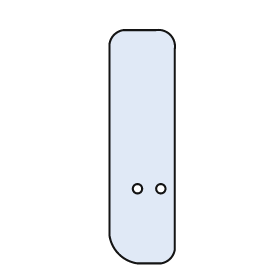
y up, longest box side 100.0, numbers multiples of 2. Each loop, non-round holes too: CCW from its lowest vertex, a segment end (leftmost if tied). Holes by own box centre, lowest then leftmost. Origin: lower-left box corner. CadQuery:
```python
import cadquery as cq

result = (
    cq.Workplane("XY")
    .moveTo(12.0, 0.0)
    .lineTo(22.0, 0.0)
    .threePointArc((26.0, 2.0), (28.0, 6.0))
    .lineTo(28.0, 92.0)
    .threePointArc((26.0, 98.0), (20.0, 100.0))
    .lineTo(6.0, 100.0)
    .threePointArc((2.0, 98.0), (0.0, 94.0))
    .lineTo(0.0, 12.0)
    .threePointArc((4.0, 4.0), (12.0, 0.0))
    .close()
    .moveTo(12.0, 32.0)
    .circle(2.0)
    .moveTo(22.0, 32.0)
    .circle(2.0)
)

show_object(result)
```